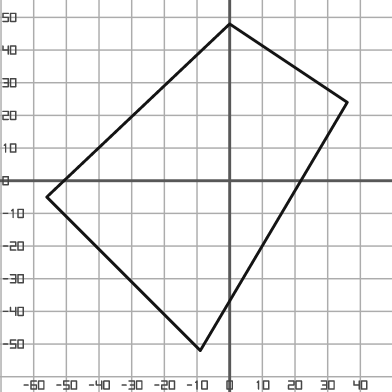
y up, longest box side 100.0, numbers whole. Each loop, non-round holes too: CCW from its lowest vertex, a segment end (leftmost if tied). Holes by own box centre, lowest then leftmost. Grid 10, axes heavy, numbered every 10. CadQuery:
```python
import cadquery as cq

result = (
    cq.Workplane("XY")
    .moveTo(-9.0, -52.0)
    .lineTo(36.0, 24.0)
    .lineTo(0.0, 48.0)
    .lineTo(-56.0, -5.0)
    .close()
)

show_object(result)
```